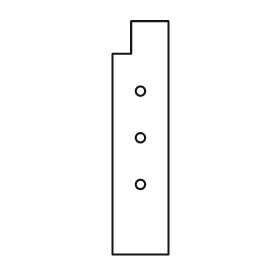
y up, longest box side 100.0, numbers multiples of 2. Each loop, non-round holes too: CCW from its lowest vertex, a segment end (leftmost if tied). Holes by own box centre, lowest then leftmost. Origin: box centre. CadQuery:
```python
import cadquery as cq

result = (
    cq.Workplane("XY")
    .moveTo(-12.0, -50.0)
    .lineTo(12.0, -50.0)
    .lineTo(12.0, 50.0)
    .lineTo(-4.0, 50.0)
    .lineTo(-4.0, 36.0)
    .lineTo(-12.0, 36.0)
    .close()
    .moveTo(0.0, -20.0)
    .circle(2.0)
    .moveTo(0.0, 0.0)
    .circle(2.0)
    .moveTo(0.0, 20.0)
    .circle(2.0)
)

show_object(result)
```